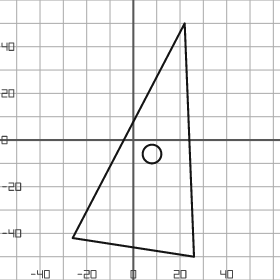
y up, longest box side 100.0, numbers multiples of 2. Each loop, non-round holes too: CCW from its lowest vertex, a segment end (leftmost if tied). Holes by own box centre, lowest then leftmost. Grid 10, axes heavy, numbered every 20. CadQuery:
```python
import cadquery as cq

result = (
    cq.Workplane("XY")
    .moveTo(26.0, -50.0)
    .lineTo(22.0, 50.0)
    .lineTo(-26.0, -42.0)
    .close()
    .moveTo(8.0, -6.0)
    .circle(4.0)
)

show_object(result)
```